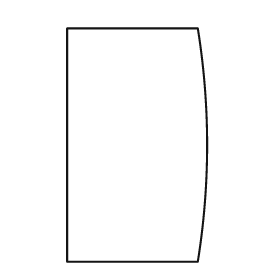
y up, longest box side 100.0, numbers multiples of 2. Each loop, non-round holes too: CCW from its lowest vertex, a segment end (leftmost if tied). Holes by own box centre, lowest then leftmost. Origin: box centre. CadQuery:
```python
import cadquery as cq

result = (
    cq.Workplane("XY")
    .moveTo(-30.0, -50.0)
    .lineTo(26.0, -50.0)
    .threePointArc((30.0, 0.0), (26.0, 50.0))
    .lineTo(-30.0, 50.0)
    .close()
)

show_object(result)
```